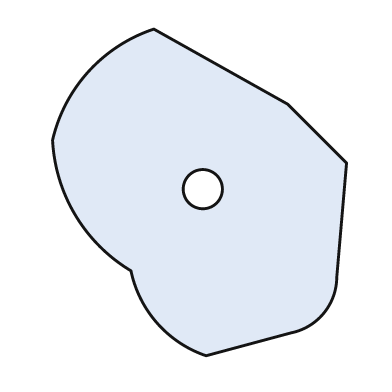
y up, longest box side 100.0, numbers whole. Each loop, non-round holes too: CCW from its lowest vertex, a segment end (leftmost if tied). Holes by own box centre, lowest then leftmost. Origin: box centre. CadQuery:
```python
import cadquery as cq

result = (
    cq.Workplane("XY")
    .moveTo(2.0, -50.0)
    .lineTo(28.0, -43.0)
    .threePointArc((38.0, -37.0), (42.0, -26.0))
    .lineTo(45.0, 9.0)
    .lineTo(27.0, 27.0)
    .lineTo(-14.0, 50.0)
    .threePointArc((-34.0, 37.0), (-45.0, 16.0))
    .threePointArc((-38.0, -7.0), (-21.0, -24.0))
    .threePointArc((-13.0, -40.0), (2.0, -50.0))
    .close()
    .moveTo(1.0, 1.0)
    .circle(6.0)
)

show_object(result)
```